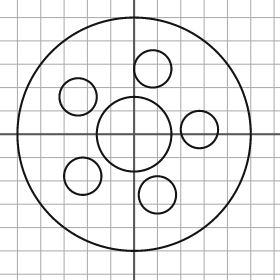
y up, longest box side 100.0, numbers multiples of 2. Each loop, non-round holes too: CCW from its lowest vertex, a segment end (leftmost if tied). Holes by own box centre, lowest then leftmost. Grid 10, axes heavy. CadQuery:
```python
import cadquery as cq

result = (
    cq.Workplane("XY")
    .moveTo(0.0, 0.0)
    .circle(50.0)
    .moveTo(10.0, -26.0)
    .circle(8.0)
    .moveTo(-22.0, -18.0)
    .circle(8.0)
    .moveTo(0.0, 0.0)
    .circle(16.0)
    .moveTo(28.0, 2.0)
    .circle(8.0)
    .moveTo(-24.0, 16.0)
    .circle(8.0)
    .moveTo(8.0, 28.0)
    .circle(8.0)
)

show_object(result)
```